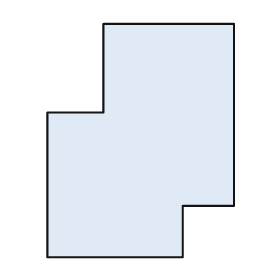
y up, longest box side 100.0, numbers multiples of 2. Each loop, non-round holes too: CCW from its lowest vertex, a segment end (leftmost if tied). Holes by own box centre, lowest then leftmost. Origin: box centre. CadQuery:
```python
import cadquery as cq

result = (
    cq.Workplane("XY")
    .moveTo(-40.0, -50.0)
    .lineTo(18.0, -50.0)
    .lineTo(18.0, -28.0)
    .lineTo(40.0, -28.0)
    .lineTo(40.0, 50.0)
    .lineTo(-16.0, 50.0)
    .lineTo(-16.0, 12.0)
    .lineTo(-40.0, 12.0)
    .close()
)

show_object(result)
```